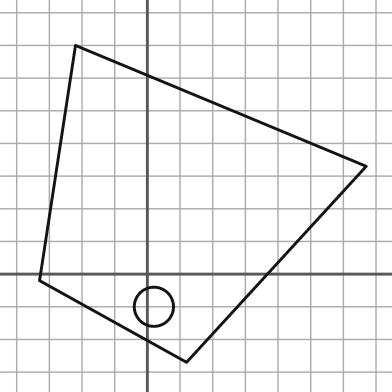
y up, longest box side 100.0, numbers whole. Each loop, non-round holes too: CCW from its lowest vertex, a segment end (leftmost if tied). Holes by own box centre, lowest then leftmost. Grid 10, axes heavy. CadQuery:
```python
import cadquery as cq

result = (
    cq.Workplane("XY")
    .moveTo(12.0, -27.0)
    .lineTo(67.0, 33.0)
    .lineTo(-22.0, 70.0)
    .lineTo(-33.0, -2.0)
    .close()
    .moveTo(2.0, -10.0)
    .circle(6.0)
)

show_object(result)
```